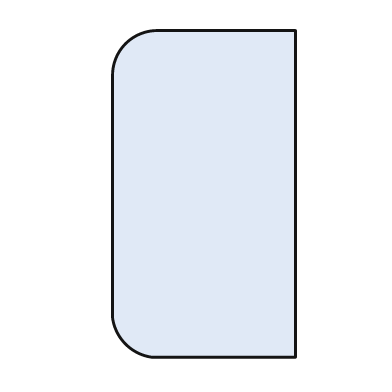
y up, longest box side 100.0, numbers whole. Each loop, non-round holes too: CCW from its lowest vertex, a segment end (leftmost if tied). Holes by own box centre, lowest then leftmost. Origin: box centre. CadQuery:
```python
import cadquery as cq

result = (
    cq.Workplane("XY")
    .moveTo(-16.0, -50.0)
    .lineTo(28.0, -50.0)
    .lineTo(28.0, 50.0)
    .lineTo(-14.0, 50.0)
    .threePointArc((-24.0, 46.0), (-28.0, 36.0))
    .lineTo(-28.0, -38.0)
    .threePointArc((-24.0, -46.0), (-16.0, -50.0))
    .close()
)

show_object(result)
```